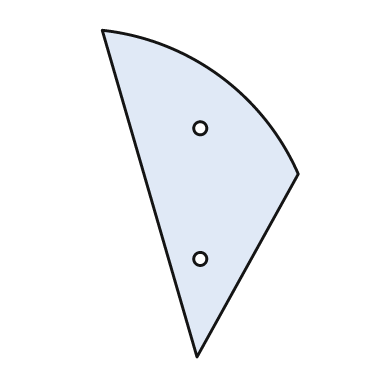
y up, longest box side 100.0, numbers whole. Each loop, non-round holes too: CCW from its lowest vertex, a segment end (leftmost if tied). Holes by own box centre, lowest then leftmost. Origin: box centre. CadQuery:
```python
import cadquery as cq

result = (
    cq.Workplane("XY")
    .moveTo(-1.0, -50.0)
    .lineTo(30.0, 6.0)
    .threePointArc((6.0, 36.0), (-30.0, 50.0))
    .close()
    .moveTo(0.0, -20.0)
    .circle(2.0)
    .moveTo(0.0, 20.0)
    .circle(2.0)
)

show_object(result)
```